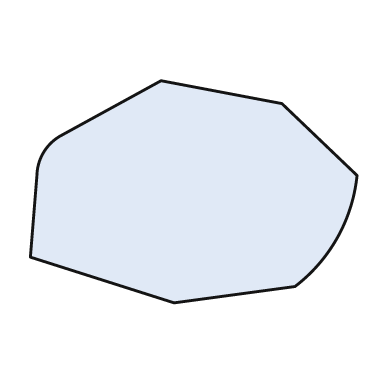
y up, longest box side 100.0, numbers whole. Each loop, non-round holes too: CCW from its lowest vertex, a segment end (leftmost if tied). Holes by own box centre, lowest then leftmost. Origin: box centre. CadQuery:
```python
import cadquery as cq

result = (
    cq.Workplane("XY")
    .moveTo(-6.0, -34.0)
    .lineTo(31.0, -29.0)
    .threePointArc((44.0, -14.0), (50.0, 5.0))
    .lineTo(27.0, 27.0)
    .lineTo(-10.0, 34.0)
    .lineTo(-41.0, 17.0)
    .threePointArc((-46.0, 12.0), (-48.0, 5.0))
    .lineTo(-50.0, -20.0)
    .close()
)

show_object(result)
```